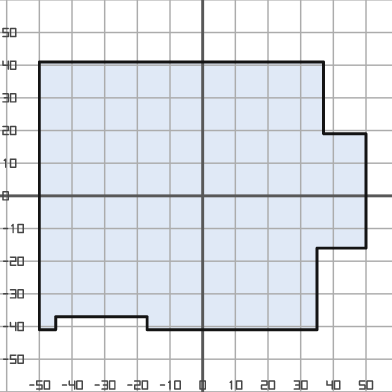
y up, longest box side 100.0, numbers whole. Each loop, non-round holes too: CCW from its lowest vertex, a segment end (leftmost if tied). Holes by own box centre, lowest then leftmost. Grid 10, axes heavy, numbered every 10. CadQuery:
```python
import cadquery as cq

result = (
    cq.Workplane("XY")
    .moveTo(-50.0, -41.0)
    .lineTo(-45.0, -41.0)
    .lineTo(-45.0, -37.0)
    .lineTo(-17.0, -37.0)
    .lineTo(-17.0, -41.0)
    .lineTo(35.0, -41.0)
    .lineTo(35.0, -16.0)
    .lineTo(50.0, -16.0)
    .lineTo(50.0, 19.0)
    .lineTo(37.0, 19.0)
    .lineTo(37.0, 41.0)
    .lineTo(-50.0, 41.0)
    .close()
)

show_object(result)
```